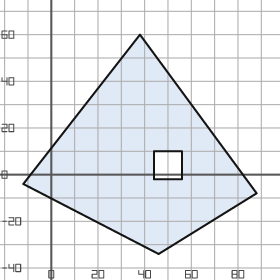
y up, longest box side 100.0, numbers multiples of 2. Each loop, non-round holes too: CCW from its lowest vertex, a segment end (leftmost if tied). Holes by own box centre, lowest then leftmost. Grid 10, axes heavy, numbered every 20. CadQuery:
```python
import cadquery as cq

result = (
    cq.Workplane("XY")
    .moveTo(46.0, -34.0)
    .lineTo(88.0, -8.0)
    .lineTo(38.0, 60.0)
    .lineTo(-12.0, -4.0)
    .close()
    .moveTo(44.0, -2.0)
    .lineTo(56.0, -2.0)
    .lineTo(56.0, 10.0)
    .lineTo(44.0, 10.0)
    .close()
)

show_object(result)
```